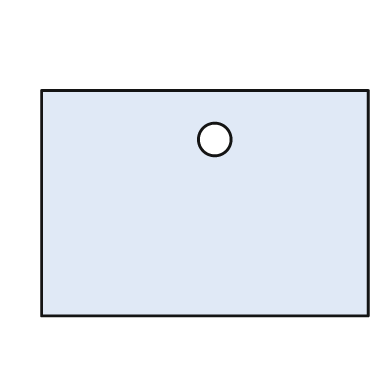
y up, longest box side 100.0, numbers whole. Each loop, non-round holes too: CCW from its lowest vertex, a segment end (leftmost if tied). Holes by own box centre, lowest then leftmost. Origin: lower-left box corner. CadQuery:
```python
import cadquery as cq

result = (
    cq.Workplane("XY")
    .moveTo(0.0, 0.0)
    .lineTo(100.0, 0.0)
    .lineTo(100.0, 69.0)
    .lineTo(0.0, 69.0)
    .close()
    .moveTo(53.0, 54.0)
    .circle(5.0)
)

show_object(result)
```